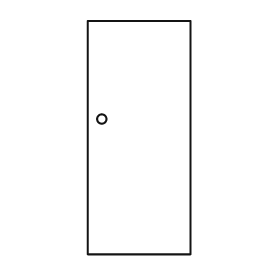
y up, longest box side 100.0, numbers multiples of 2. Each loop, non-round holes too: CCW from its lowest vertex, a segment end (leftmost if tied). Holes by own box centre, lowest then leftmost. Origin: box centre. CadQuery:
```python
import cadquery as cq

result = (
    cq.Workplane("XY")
    .moveTo(-22.0, -50.0)
    .lineTo(22.0, -50.0)
    .lineTo(22.0, 50.0)
    .lineTo(-22.0, 50.0)
    .close()
    .moveTo(-16.0, 8.0)
    .circle(2.0)
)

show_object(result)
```